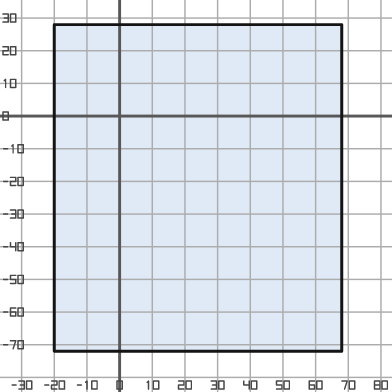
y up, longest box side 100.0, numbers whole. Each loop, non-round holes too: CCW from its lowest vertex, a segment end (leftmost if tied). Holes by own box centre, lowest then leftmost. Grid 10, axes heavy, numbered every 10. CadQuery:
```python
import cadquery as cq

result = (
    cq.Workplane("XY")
    .moveTo(-20.0, -72.0)
    .lineTo(68.0, -72.0)
    .lineTo(68.0, 28.0)
    .lineTo(-20.0, 28.0)
    .close()
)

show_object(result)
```